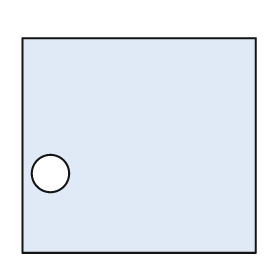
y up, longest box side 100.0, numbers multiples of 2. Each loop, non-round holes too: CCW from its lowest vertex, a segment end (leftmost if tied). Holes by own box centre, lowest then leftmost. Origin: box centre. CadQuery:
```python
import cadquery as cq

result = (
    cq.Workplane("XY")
    .moveTo(-50.0, -46.0)
    .lineTo(50.0, -46.0)
    .lineTo(50.0, 46.0)
    .lineTo(-50.0, 46.0)
    .close()
    .moveTo(-38.0, -12.0)
    .circle(8.0)
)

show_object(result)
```